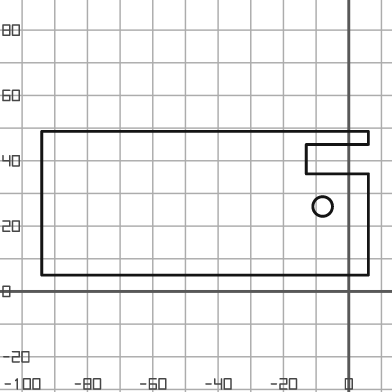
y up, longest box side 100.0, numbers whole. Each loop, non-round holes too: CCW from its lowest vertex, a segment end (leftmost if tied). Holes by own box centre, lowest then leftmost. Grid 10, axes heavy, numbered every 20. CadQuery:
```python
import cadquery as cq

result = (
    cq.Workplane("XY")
    .moveTo(-94.0, 5.0)
    .lineTo(6.0, 5.0)
    .lineTo(6.0, 36.0)
    .lineTo(-13.0, 36.0)
    .lineTo(-13.0, 45.0)
    .lineTo(6.0, 45.0)
    .lineTo(6.0, 49.0)
    .lineTo(-94.0, 49.0)
    .close()
    .moveTo(-8.0, 26.0)
    .circle(3.0)
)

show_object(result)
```